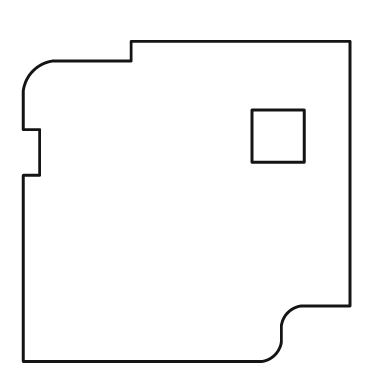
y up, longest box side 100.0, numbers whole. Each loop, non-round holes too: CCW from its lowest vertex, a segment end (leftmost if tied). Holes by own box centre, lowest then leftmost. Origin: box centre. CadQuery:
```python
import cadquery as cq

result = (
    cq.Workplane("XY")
    .moveTo(-50.0, -49.0)
    .lineTo(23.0, -49.0)
    .threePointArc((27.0, -47.0), (29.0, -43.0))
    .lineTo(29.0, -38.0)
    .threePointArc((31.0, -34.0), (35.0, -32.0))
    .lineTo(50.0, -32.0)
    .lineTo(50.0, 49.0)
    .lineTo(-17.0, 49.0)
    .lineTo(-17.0, 43.0)
    .lineTo(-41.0, 43.0)
    .threePointArc((-47.0, 40.0), (-50.0, 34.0))
    .lineTo(-50.0, 22.0)
    .lineTo(-45.0, 22.0)
    .lineTo(-45.0, 8.0)
    .lineTo(-50.0, 8.0)
    .close()
    .moveTo(20.0, 12.0)
    .lineTo(36.0, 12.0)
    .lineTo(36.0, 28.0)
    .lineTo(20.0, 28.0)
    .close()
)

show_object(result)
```